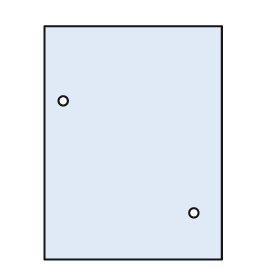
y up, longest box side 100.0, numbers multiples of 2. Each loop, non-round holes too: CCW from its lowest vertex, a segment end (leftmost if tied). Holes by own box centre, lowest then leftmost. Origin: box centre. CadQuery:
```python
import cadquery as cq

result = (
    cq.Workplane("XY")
    .moveTo(-38.0, -50.0)
    .lineTo(38.0, -50.0)
    .lineTo(38.0, 50.0)
    .lineTo(-38.0, 50.0)
    .close()
    .moveTo(26.0, -30.0)
    .circle(2.0)
    .moveTo(-30.0, 18.0)
    .circle(2.0)
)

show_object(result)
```